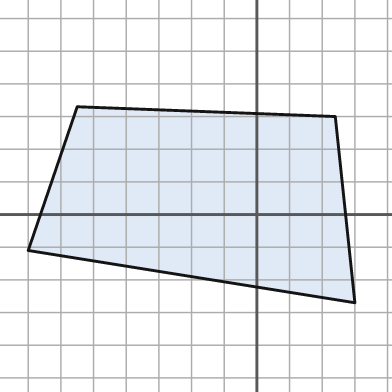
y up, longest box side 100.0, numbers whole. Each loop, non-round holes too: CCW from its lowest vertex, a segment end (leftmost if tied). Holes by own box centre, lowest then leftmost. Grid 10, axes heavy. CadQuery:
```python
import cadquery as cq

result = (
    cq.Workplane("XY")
    .moveTo(30.0, -27.0)
    .lineTo(24.0, 30.0)
    .lineTo(-55.0, 33.0)
    .lineTo(-70.0, -11.0)
    .close()
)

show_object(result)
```